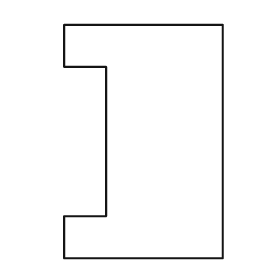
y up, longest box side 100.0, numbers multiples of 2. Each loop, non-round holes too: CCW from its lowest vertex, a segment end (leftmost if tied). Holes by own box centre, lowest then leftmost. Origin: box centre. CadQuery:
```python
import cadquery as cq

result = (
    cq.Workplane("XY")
    .moveTo(-34.0, -50.0)
    .lineTo(34.0, -50.0)
    .lineTo(34.0, 50.0)
    .lineTo(-34.0, 50.0)
    .lineTo(-34.0, 32.0)
    .lineTo(-16.0, 32.0)
    .lineTo(-16.0, -32.0)
    .lineTo(-34.0, -32.0)
    .close()
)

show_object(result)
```